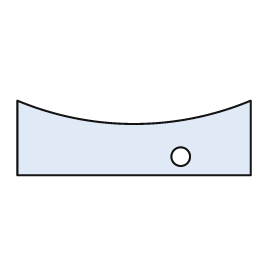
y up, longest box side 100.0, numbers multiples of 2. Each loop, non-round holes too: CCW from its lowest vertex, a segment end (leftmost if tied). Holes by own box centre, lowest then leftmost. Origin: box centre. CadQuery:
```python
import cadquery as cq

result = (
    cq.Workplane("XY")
    .moveTo(-50.0, -16.0)
    .lineTo(50.0, -16.0)
    .lineTo(50.0, 16.0)
    .threePointArc((0.0, 6.0), (-50.0, 16.0))
    .close()
    .moveTo(20.0, -8.0)
    .circle(4.0)
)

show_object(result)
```